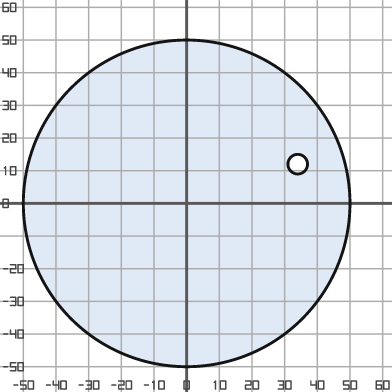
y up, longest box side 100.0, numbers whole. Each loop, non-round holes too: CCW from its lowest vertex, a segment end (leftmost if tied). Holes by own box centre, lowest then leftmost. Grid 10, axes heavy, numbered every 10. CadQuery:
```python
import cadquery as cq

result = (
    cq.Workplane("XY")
    .moveTo(0.0, 0.0)
    .circle(50.0)
    .moveTo(34.0, 12.0)
    .circle(3.0)
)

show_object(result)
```